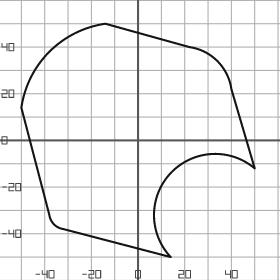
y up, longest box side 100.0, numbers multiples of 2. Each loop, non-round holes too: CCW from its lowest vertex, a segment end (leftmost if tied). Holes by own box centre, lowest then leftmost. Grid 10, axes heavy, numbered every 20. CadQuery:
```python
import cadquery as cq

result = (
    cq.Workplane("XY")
    .moveTo(14.0, -50.0)
    .threePointArc((14.0, -14.0), (50.0, -12.0))
    .lineTo(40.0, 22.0)
    .threePointArc((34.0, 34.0), (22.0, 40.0))
    .lineTo(-14.0, 50.0)
    .threePointArc((-38.0, 38.0), (-50.0, 14.0))
    .lineTo(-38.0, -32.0)
    .threePointArc((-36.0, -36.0), (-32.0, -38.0))
    .close()
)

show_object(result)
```